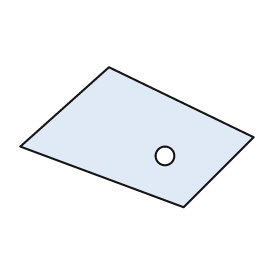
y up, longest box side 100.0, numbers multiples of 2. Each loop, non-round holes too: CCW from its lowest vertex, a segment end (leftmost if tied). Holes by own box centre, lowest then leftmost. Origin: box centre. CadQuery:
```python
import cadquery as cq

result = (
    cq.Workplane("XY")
    .moveTo(20.0, -30.0)
    .lineTo(50.0, 0.0)
    .lineTo(-12.0, 30.0)
    .lineTo(-50.0, -4.0)
    .close()
    .moveTo(12.0, -8.0)
    .circle(4.0)
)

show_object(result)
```